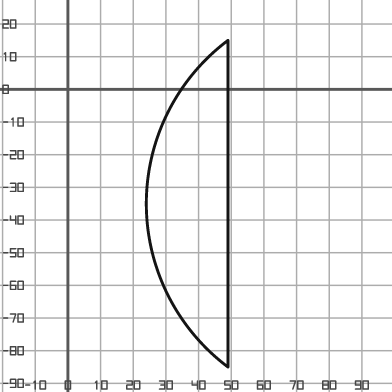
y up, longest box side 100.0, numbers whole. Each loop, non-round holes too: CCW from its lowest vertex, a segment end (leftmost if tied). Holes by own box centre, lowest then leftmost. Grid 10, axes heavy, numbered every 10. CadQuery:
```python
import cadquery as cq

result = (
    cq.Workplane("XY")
    .moveTo(49.0, -85.0)
    .lineTo(49.0, 15.0)
    .threePointArc((24.0, -35.0), (49.0, -85.0))
    .close()
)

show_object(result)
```